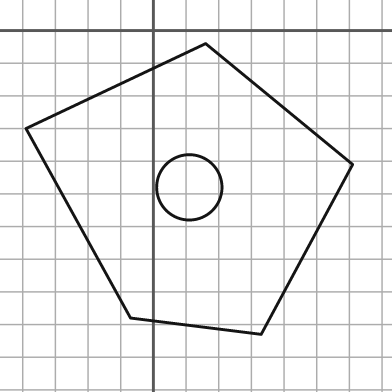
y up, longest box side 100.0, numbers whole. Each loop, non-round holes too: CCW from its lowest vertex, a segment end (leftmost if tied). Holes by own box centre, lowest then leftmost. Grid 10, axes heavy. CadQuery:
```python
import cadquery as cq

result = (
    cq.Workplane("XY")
    .moveTo(33.0, -93.0)
    .lineTo(61.0, -41.0)
    .lineTo(16.0, -4.0)
    .lineTo(-39.0, -30.0)
    .lineTo(-7.0, -88.0)
    .close()
    .moveTo(11.0, -48.0)
    .circle(10.0)
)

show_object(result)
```